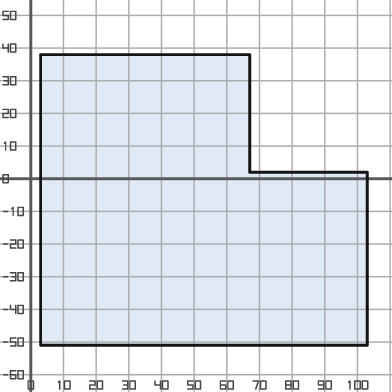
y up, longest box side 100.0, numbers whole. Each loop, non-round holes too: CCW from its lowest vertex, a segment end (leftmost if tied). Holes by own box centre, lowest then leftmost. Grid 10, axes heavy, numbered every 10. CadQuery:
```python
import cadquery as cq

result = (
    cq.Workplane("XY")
    .moveTo(3.0, -51.0)
    .lineTo(103.0, -51.0)
    .lineTo(103.0, 2.0)
    .lineTo(67.0, 2.0)
    .lineTo(67.0, 38.0)
    .lineTo(3.0, 38.0)
    .close()
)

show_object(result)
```